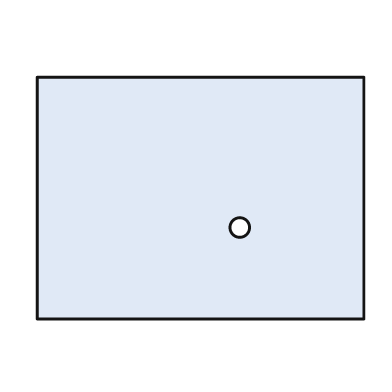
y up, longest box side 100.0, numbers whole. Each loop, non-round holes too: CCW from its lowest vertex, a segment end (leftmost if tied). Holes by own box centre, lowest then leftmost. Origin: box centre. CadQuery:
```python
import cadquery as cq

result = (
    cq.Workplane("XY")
    .moveTo(-50.0, -37.0)
    .lineTo(50.0, -37.0)
    .lineTo(50.0, 37.0)
    .lineTo(-50.0, 37.0)
    .close()
    .moveTo(12.0, -9.0)
    .circle(3.0)
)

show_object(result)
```